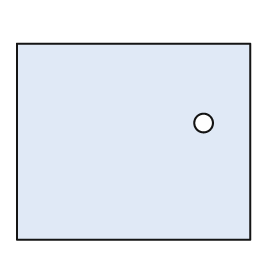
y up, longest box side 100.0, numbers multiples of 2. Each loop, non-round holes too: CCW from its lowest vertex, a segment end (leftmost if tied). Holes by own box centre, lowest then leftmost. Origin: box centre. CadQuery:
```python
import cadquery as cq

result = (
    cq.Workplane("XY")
    .moveTo(-50.0, -42.0)
    .lineTo(50.0, -42.0)
    .lineTo(50.0, 42.0)
    .lineTo(-50.0, 42.0)
    .close()
    .moveTo(30.0, 8.0)
    .circle(4.0)
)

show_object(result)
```